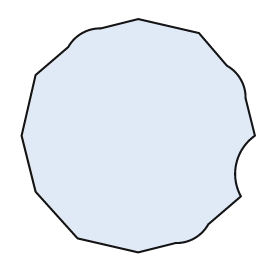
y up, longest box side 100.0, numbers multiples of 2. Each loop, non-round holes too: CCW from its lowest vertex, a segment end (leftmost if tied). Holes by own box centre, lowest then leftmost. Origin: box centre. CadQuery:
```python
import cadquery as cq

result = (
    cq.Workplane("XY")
    .moveTo(0.0, -50.0)
    .lineTo(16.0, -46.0)
    .threePointArc((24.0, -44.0), (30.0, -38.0))
    .lineTo(44.0, -26.0)
    .threePointArc((42.0, -12.0), (50.0, 0.0))
    .lineTo(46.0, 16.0)
    .threePointArc((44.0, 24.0), (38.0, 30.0))
    .lineTo(26.0, 44.0)
    .lineTo(0.0, 50.0)
    .lineTo(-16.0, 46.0)
    .threePointArc((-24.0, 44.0), (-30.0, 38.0))
    .lineTo(-44.0, 26.0)
    .lineTo(-50.0, 0.0)
    .lineTo(-44.0, -24.0)
    .lineTo(-26.0, -44.0)
    .close()
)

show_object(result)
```